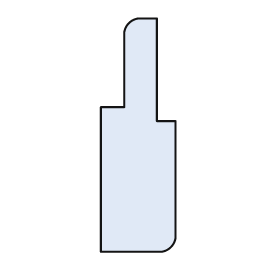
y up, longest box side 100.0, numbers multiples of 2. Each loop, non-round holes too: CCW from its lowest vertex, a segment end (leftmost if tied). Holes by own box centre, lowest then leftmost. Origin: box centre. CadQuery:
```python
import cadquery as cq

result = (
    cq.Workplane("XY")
    .moveTo(-16.0, -50.0)
    .lineTo(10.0, -50.0)
    .threePointArc((14.0, -48.0), (16.0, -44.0))
    .lineTo(16.0, 6.0)
    .lineTo(8.0, 6.0)
    .lineTo(8.0, 50.0)
    .lineTo(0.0, 50.0)
    .threePointArc((-4.0, 48.0), (-6.0, 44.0))
    .lineTo(-6.0, 12.0)
    .lineTo(-16.0, 12.0)
    .close()
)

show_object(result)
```